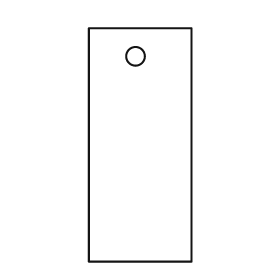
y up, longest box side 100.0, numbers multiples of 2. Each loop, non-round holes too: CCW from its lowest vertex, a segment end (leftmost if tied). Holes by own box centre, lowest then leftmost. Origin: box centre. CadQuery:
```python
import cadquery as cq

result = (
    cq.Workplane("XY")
    .moveTo(-22.0, -50.0)
    .lineTo(22.0, -50.0)
    .lineTo(22.0, 50.0)
    .lineTo(-22.0, 50.0)
    .close()
    .moveTo(-2.0, 38.0)
    .circle(4.0)
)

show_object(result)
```